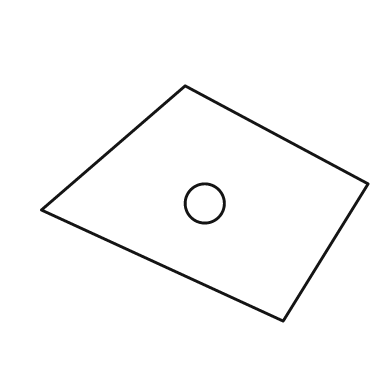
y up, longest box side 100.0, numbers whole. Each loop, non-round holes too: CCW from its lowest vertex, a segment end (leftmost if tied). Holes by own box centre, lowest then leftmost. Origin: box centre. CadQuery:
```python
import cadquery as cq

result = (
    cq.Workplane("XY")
    .moveTo(24.0, -36.0)
    .lineTo(50.0, 6.0)
    .lineTo(-6.0, 36.0)
    .lineTo(-50.0, -2.0)
    .close()
    .moveTo(0.0, 0.0)
    .circle(6.0)
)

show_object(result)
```